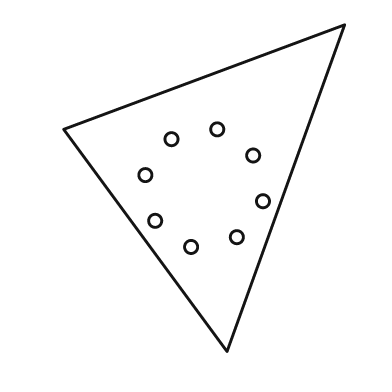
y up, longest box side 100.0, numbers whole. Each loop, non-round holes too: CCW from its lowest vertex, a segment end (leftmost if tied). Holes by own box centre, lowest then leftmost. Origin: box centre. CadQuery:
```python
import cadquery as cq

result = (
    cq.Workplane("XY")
    .moveTo(7.0, -50.0)
    .lineTo(43.0, 50.0)
    .lineTo(-43.0, 18.0)
    .close()
    .moveTo(-4.0, -18.0)
    .circle(2.0)
    .moveTo(10.0, -15.0)
    .circle(2.0)
    .moveTo(-15.0, -10.0)
    .circle(2.0)
    .moveTo(18.0, -4.0)
    .circle(2.0)
    .moveTo(-18.0, 4.0)
    .circle(2.0)
    .moveTo(15.0, 10.0)
    .circle(2.0)
    .moveTo(-10.0, 15.0)
    .circle(2.0)
    .moveTo(4.0, 18.0)
    .circle(2.0)
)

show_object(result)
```